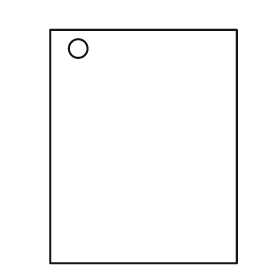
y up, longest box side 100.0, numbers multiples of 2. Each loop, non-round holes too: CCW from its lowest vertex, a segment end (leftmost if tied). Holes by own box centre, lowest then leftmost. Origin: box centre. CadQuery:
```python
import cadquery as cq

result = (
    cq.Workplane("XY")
    .moveTo(-40.0, -50.0)
    .lineTo(40.0, -50.0)
    .lineTo(40.0, 50.0)
    .lineTo(-40.0, 50.0)
    .close()
    .moveTo(-28.0, 42.0)
    .circle(4.0)
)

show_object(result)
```